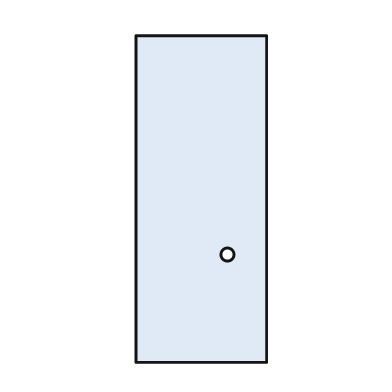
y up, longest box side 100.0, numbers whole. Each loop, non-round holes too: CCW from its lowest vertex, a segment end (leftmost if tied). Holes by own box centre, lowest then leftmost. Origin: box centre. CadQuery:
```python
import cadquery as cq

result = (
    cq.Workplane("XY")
    .moveTo(-20.0, -50.0)
    .lineTo(20.0, -50.0)
    .lineTo(20.0, 50.0)
    .lineTo(-20.0, 50.0)
    .close()
    .moveTo(8.0, -17.0)
    .circle(2.0)
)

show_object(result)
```